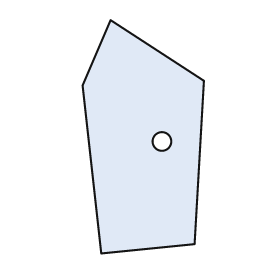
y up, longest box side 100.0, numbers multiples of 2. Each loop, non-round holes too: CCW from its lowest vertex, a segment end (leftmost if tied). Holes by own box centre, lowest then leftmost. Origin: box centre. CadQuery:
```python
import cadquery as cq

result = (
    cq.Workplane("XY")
    .moveTo(-18.0, -50.0)
    .lineTo(22.0, -46.0)
    .lineTo(26.0, 24.0)
    .lineTo(-14.0, 50.0)
    .lineTo(-26.0, 22.0)
    .close()
    .moveTo(8.0, -2.0)
    .circle(4.0)
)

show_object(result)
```